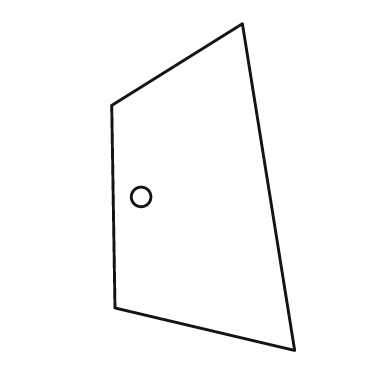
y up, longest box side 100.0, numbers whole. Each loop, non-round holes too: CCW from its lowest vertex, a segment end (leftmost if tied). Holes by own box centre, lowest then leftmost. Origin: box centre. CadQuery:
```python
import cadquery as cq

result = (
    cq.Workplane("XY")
    .moveTo(28.0, -50.0)
    .lineTo(12.0, 50.0)
    .lineTo(-28.0, 25.0)
    .lineTo(-27.0, -37.0)
    .close()
    .moveTo(-19.0, -3.0)
    .circle(3.0)
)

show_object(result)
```